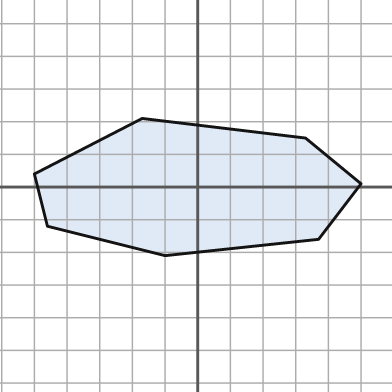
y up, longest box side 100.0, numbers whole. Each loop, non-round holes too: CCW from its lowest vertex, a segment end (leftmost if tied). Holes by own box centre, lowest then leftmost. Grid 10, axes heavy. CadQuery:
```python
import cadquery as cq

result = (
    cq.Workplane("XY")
    .moveTo(-10.0, -21.0)
    .lineTo(37.0, -16.0)
    .lineTo(50.0, 1.0)
    .lineTo(33.0, 15.0)
    .lineTo(-17.0, 21.0)
    .lineTo(-50.0, 4.0)
    .lineTo(-46.0, -12.0)
    .close()
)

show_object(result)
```